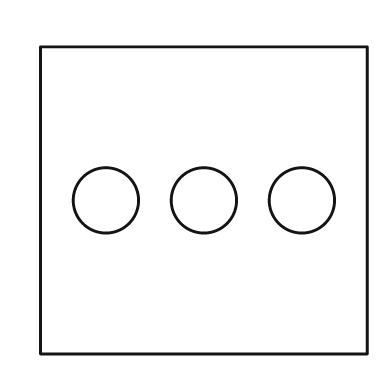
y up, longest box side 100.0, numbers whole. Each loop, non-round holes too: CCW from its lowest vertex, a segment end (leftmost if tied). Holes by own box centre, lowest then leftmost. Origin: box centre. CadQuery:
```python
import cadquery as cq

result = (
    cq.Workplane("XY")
    .moveTo(-50.0, -47.0)
    .lineTo(50.0, -47.0)
    .lineTo(50.0, 47.0)
    .lineTo(-50.0, 47.0)
    .close()
    .moveTo(-30.0, 0.0)
    .circle(10.0)
    .moveTo(0.0, 0.0)
    .circle(10.0)
    .moveTo(30.0, 0.0)
    .circle(10.0)
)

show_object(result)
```